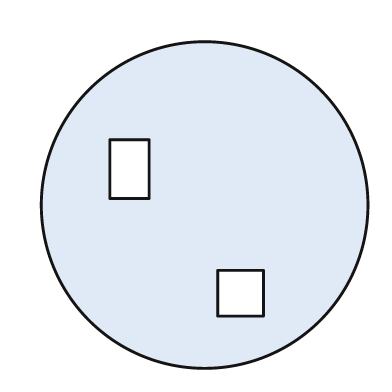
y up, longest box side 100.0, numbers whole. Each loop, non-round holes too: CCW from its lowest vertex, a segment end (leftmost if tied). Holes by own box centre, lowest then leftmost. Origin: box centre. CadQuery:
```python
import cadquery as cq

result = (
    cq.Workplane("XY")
    .moveTo(0.0, 0.0)
    .circle(50.0)
    .moveTo(4.0, -34.0)
    .lineTo(18.0, -34.0)
    .lineTo(18.0, -20.0)
    .lineTo(4.0, -20.0)
    .close()
    .moveTo(-29.0, 2.0)
    .lineTo(-17.0, 2.0)
    .lineTo(-17.0, 20.0)
    .lineTo(-29.0, 20.0)
    .close()
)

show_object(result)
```